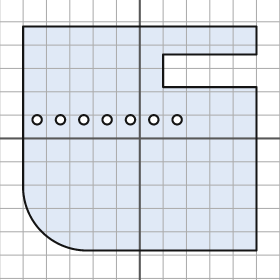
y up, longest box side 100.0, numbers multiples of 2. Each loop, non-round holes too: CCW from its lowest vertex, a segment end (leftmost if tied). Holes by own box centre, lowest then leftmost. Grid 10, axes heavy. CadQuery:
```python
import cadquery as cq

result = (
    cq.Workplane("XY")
    .moveTo(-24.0, -48.0)
    .lineTo(50.0, -48.0)
    .lineTo(50.0, 22.0)
    .lineTo(10.0, 22.0)
    .lineTo(10.0, 36.0)
    .lineTo(50.0, 36.0)
    .lineTo(50.0, 48.0)
    .lineTo(-50.0, 48.0)
    .lineTo(-50.0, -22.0)
    .threePointArc((-42.0, -40.0), (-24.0, -48.0))
    .close()
    .moveTo(-44.0, 8.0)
    .circle(2.0)
    .moveTo(-34.0, 8.0)
    .circle(2.0)
    .moveTo(-24.0, 8.0)
    .circle(2.0)
    .moveTo(-14.0, 8.0)
    .circle(2.0)
    .moveTo(-4.0, 8.0)
    .circle(2.0)
    .moveTo(6.0, 8.0)
    .circle(2.0)
    .moveTo(16.0, 8.0)
    .circle(2.0)
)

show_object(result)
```